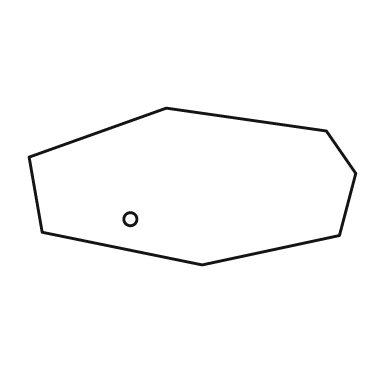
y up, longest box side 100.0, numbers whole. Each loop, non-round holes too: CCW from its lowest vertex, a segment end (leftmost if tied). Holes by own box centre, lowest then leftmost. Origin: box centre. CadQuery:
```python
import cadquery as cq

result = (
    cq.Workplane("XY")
    .moveTo(3.0, -24.0)
    .lineTo(45.0, -15.0)
    .lineTo(50.0, 4.0)
    .lineTo(41.0, 17.0)
    .lineTo(-8.0, 24.0)
    .lineTo(-50.0, 9.0)
    .lineTo(-46.0, -14.0)
    .close()
    .moveTo(-19.0, -10.0)
    .circle(2.0)
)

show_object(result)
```